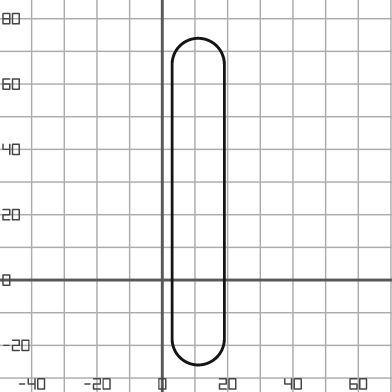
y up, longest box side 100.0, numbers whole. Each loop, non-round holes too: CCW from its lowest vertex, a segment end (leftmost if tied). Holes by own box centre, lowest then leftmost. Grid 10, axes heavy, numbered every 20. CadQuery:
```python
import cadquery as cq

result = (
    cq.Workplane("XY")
    .moveTo(3.0, -18.0)
    .threePointArc((11.0, -26.0), (19.0, -18.0))
    .lineTo(19.0, 66.0)
    .threePointArc((11.0, 74.0), (3.0, 66.0))
    .close()
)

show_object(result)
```